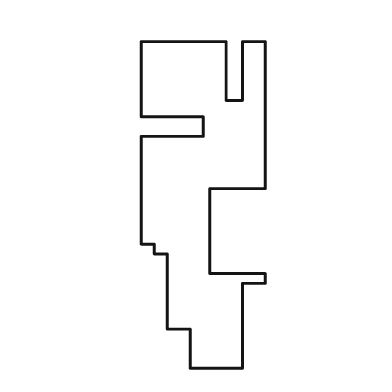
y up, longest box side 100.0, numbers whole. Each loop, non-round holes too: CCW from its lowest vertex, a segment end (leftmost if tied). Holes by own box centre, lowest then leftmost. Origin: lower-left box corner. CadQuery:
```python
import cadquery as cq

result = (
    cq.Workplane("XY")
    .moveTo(15.0, 0.0)
    .lineTo(31.0, 0.0)
    .lineTo(31.0, 26.0)
    .lineTo(38.0, 26.0)
    .lineTo(38.0, 29.0)
    .lineTo(21.0, 29.0)
    .lineTo(21.0, 55.0)
    .lineTo(38.0, 55.0)
    .lineTo(38.0, 100.0)
    .lineTo(31.0, 100.0)
    .lineTo(31.0, 82.0)
    .lineTo(26.0, 82.0)
    .lineTo(26.0, 100.0)
    .lineTo(0.0, 100.0)
    .lineTo(0.0, 77.0)
    .lineTo(19.0, 77.0)
    .lineTo(19.0, 71.0)
    .lineTo(0.0, 71.0)
    .lineTo(0.0, 38.0)
    .lineTo(4.0, 38.0)
    .lineTo(4.0, 35.0)
    .lineTo(8.0, 35.0)
    .lineTo(8.0, 12.0)
    .lineTo(15.0, 12.0)
    .close()
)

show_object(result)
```